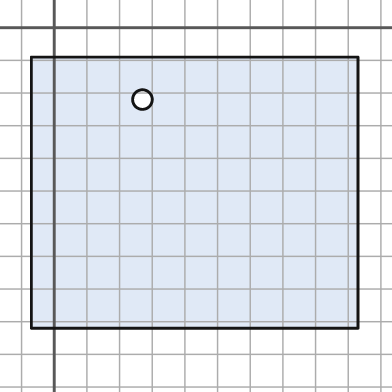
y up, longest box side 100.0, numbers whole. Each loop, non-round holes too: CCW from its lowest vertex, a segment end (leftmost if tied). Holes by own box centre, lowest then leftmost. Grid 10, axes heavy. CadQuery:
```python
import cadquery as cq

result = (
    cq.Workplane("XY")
    .moveTo(-7.0, -92.0)
    .lineTo(93.0, -92.0)
    .lineTo(93.0, -9.0)
    .lineTo(-7.0, -9.0)
    .close()
    .moveTo(27.0, -22.0)
    .circle(3.0)
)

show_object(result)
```